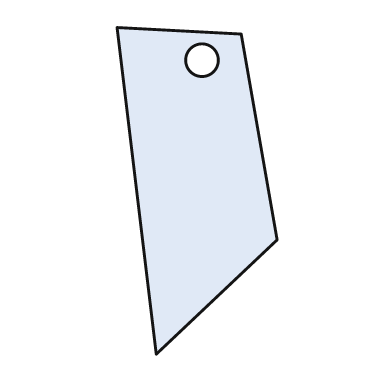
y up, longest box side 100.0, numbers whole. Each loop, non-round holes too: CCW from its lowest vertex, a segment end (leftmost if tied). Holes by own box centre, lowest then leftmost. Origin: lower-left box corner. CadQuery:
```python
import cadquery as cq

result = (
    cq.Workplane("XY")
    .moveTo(12.0, 0.0)
    .lineTo(49.0, 35.0)
    .lineTo(38.0, 98.0)
    .lineTo(0.0, 100.0)
    .close()
    .moveTo(26.0, 90.0)
    .circle(5.0)
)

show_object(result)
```